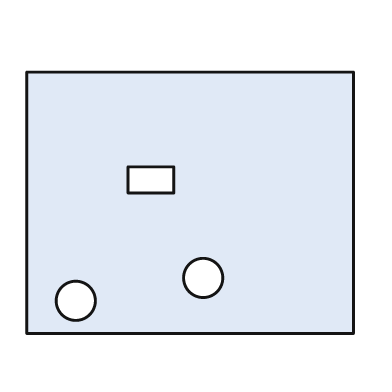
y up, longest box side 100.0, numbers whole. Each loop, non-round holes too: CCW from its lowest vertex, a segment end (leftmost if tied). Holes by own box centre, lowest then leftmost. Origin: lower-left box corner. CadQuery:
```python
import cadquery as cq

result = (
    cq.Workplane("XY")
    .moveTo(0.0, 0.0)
    .lineTo(100.0, 0.0)
    .lineTo(100.0, 80.0)
    .lineTo(0.0, 80.0)
    .close()
    .moveTo(15.0, 10.0)
    .circle(6.0)
    .moveTo(54.0, 17.0)
    .circle(6.0)
    .moveTo(31.0, 43.0)
    .lineTo(45.0, 43.0)
    .lineTo(45.0, 51.0)
    .lineTo(31.0, 51.0)
    .close()
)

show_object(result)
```